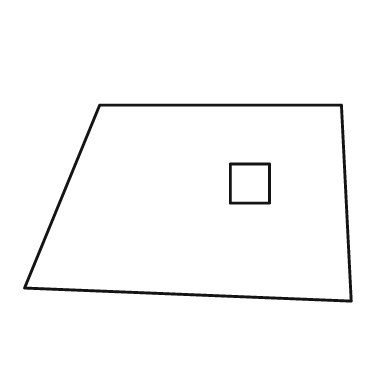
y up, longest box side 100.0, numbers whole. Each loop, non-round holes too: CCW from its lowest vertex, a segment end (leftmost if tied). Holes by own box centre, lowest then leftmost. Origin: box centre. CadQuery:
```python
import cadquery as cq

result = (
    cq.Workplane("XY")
    .moveTo(50.0, -30.0)
    .lineTo(47.0, 30.0)
    .lineTo(-27.0, 30.0)
    .lineTo(-50.0, -26.0)
    .close()
    .moveTo(13.0, 0.0)
    .lineTo(25.0, 0.0)
    .lineTo(25.0, 12.0)
    .lineTo(13.0, 12.0)
    .close()
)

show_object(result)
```